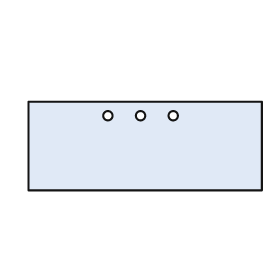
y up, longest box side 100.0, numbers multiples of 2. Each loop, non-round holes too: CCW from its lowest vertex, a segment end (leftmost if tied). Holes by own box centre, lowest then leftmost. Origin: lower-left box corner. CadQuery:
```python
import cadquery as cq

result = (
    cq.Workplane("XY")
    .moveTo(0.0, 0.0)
    .lineTo(100.0, 0.0)
    .lineTo(100.0, 38.0)
    .lineTo(0.0, 38.0)
    .close()
    .moveTo(34.0, 32.0)
    .circle(2.0)
    .moveTo(48.0, 32.0)
    .circle(2.0)
    .moveTo(62.0, 32.0)
    .circle(2.0)
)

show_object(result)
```